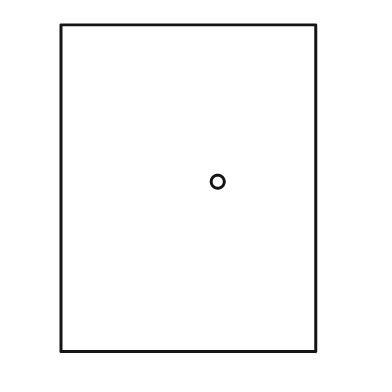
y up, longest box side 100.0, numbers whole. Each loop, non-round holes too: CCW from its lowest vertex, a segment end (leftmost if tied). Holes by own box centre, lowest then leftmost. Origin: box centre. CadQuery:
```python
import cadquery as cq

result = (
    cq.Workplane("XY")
    .moveTo(-39.0, -50.0)
    .lineTo(39.0, -50.0)
    .lineTo(39.0, 50.0)
    .lineTo(-39.0, 50.0)
    .close()
    .moveTo(9.0, 2.0)
    .circle(2.0)
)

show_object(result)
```